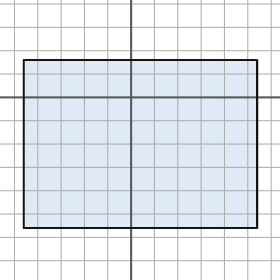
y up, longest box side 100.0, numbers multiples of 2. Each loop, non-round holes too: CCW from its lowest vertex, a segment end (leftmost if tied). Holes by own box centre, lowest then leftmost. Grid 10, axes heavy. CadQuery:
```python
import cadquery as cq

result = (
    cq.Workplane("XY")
    .moveTo(-46.0, -56.0)
    .lineTo(54.0, -56.0)
    .lineTo(54.0, 16.0)
    .lineTo(-46.0, 16.0)
    .close()
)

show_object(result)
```